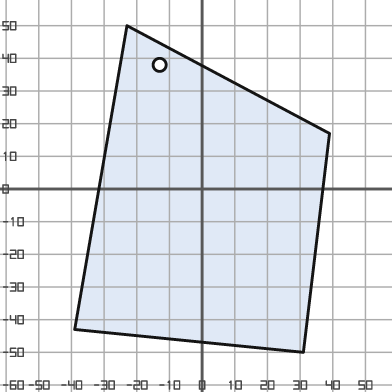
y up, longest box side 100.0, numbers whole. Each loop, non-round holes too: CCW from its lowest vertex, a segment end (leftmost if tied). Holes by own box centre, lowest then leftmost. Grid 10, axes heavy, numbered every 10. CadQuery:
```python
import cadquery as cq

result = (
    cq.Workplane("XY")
    .moveTo(31.0, -50.0)
    .lineTo(39.0, 17.0)
    .lineTo(-23.0, 50.0)
    .lineTo(-39.0, -43.0)
    .close()
    .moveTo(-13.0, 38.0)
    .circle(2.0)
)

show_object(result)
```